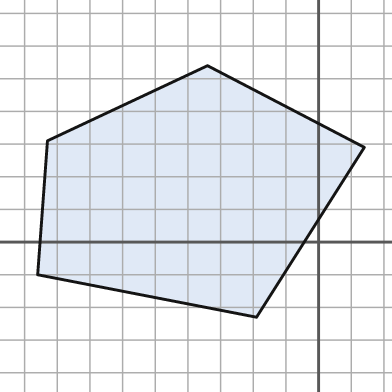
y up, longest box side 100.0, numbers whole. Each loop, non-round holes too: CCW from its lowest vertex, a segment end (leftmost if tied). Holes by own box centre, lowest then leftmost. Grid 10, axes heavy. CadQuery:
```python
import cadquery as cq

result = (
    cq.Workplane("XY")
    .moveTo(-19.0, -23.0)
    .lineTo(14.0, 29.0)
    .lineTo(-34.0, 54.0)
    .lineTo(-83.0, 31.0)
    .lineTo(-86.0, -10.0)
    .close()
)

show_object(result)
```